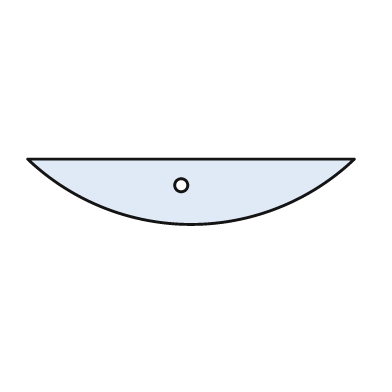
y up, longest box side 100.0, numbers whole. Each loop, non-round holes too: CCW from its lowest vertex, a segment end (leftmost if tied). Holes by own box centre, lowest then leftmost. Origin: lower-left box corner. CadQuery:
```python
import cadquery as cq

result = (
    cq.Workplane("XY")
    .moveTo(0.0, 20.0)
    .threePointArc((50.0, 0.0), (100.0, 20.0))
    .close()
    .moveTo(47.0, 12.0)
    .circle(2.0)
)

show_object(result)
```